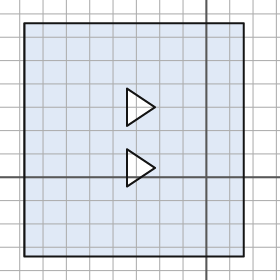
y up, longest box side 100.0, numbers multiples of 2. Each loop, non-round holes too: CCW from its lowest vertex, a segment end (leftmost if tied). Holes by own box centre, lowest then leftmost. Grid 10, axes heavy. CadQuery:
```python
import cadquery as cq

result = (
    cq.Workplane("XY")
    .moveTo(-78.0, -34.0)
    .lineTo(16.0, -34.0)
    .lineTo(16.0, 66.0)
    .lineTo(-78.0, 66.0)
    .close()
    .moveTo(-34.0, -4.0)
    .lineTo(-22.0, 4.0)
    .lineTo(-34.0, 12.0)
    .close()
    .moveTo(-34.0, 22.0)
    .lineTo(-22.0, 30.0)
    .lineTo(-34.0, 38.0)
    .close()
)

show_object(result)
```